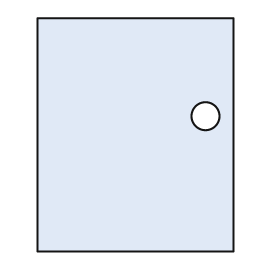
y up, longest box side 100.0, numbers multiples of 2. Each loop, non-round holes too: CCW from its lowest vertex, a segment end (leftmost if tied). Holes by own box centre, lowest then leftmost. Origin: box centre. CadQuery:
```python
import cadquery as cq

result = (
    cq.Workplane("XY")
    .moveTo(-42.0, -50.0)
    .lineTo(42.0, -50.0)
    .lineTo(42.0, 50.0)
    .lineTo(-42.0, 50.0)
    .close()
    .moveTo(30.0, 8.0)
    .circle(6.0)
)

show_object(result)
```